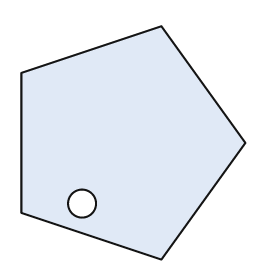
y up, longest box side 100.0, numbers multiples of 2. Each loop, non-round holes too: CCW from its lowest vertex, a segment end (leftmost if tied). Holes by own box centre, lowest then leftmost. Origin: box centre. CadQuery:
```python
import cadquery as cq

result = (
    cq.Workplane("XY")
    .moveTo(12.0, -50.0)
    .lineTo(48.0, 0.0)
    .lineTo(12.0, 50.0)
    .lineTo(-48.0, 30.0)
    .lineTo(-48.0, -30.0)
    .close()
    .moveTo(-22.0, -26.0)
    .circle(6.0)
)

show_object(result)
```